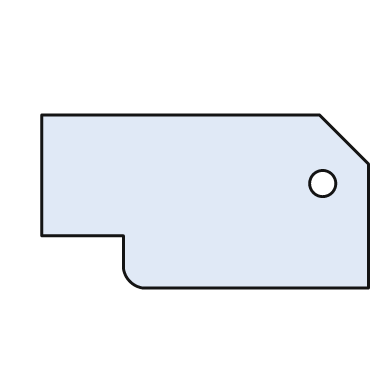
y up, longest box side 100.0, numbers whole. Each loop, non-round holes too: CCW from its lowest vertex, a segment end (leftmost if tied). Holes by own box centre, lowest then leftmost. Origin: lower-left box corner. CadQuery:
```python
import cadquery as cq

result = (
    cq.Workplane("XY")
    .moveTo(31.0, 0.0)
    .lineTo(100.0, 0.0)
    .lineTo(100.0, 38.0)
    .lineTo(85.0, 53.0)
    .lineTo(0.0, 53.0)
    .lineTo(0.0, 16.0)
    .lineTo(25.0, 16.0)
    .lineTo(25.0, 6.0)
    .threePointArc((27.0, 2.0), (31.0, 0.0))
    .close()
    .moveTo(86.0, 32.0)
    .circle(4.0)
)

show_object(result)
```